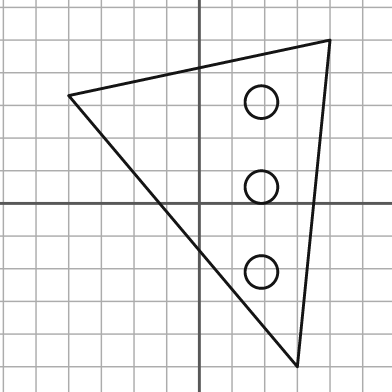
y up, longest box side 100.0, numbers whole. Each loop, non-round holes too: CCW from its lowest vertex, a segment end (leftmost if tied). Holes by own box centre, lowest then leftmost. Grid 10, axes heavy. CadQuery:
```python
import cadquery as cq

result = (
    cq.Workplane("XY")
    .moveTo(30.0, -50.0)
    .lineTo(40.0, 50.0)
    .lineTo(-40.0, 33.0)
    .close()
    .moveTo(19.0, -21.0)
    .circle(5.0)
    .moveTo(19.0, 5.0)
    .circle(5.0)
    .moveTo(19.0, 31.0)
    .circle(5.0)
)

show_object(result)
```